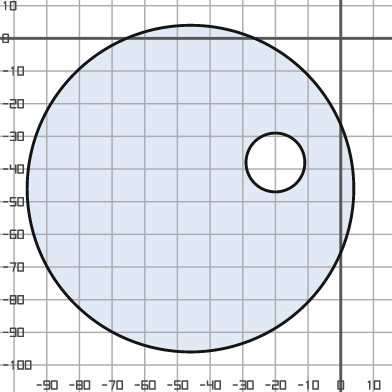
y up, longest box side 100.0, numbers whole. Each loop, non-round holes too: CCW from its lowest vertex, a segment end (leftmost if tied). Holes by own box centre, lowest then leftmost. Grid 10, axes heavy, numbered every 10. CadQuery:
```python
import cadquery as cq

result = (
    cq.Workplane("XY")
    .moveTo(-46.0, -46.0)
    .circle(50.0)
    .moveTo(-20.0, -38.0)
    .circle(9.0)
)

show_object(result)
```